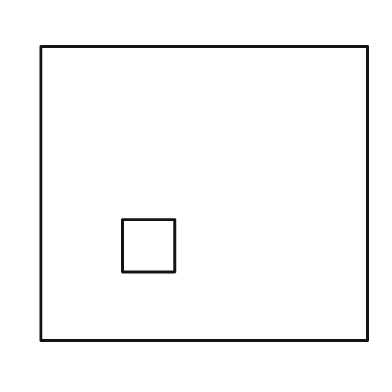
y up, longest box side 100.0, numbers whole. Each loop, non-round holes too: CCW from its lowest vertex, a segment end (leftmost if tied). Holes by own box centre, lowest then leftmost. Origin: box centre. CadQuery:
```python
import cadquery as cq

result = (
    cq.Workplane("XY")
    .moveTo(-50.0, -45.0)
    .lineTo(50.0, -45.0)
    .lineTo(50.0, 45.0)
    .lineTo(-50.0, 45.0)
    .close()
    .moveTo(-25.0, -24.0)
    .lineTo(-9.0, -24.0)
    .lineTo(-9.0, -8.0)
    .lineTo(-25.0, -8.0)
    .close()
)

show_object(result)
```